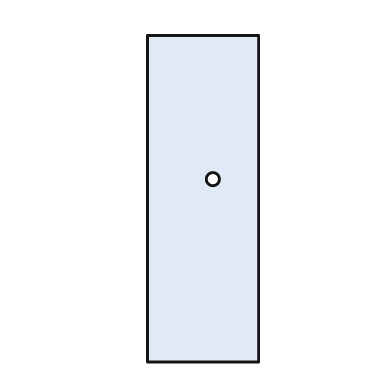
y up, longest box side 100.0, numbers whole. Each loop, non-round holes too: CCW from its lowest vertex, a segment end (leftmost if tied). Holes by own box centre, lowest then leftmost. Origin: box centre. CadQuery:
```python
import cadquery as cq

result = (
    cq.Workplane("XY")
    .moveTo(-17.0, -50.0)
    .lineTo(17.0, -50.0)
    .lineTo(17.0, 50.0)
    .lineTo(-17.0, 50.0)
    .close()
    .moveTo(3.0, 6.0)
    .circle(2.0)
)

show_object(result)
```